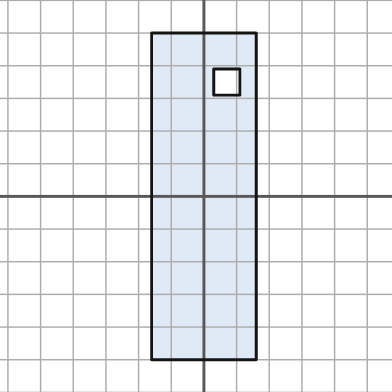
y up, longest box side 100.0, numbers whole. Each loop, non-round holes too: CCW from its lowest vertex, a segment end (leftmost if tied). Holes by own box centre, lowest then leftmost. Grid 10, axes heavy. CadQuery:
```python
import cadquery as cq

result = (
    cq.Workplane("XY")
    .moveTo(-16.0, -50.0)
    .lineTo(16.0, -50.0)
    .lineTo(16.0, 50.0)
    .lineTo(-16.0, 50.0)
    .close()
    .moveTo(3.0, 31.0)
    .lineTo(11.0, 31.0)
    .lineTo(11.0, 39.0)
    .lineTo(3.0, 39.0)
    .close()
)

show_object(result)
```